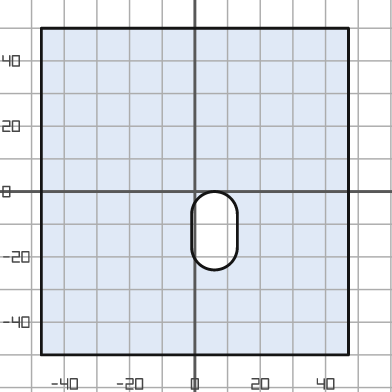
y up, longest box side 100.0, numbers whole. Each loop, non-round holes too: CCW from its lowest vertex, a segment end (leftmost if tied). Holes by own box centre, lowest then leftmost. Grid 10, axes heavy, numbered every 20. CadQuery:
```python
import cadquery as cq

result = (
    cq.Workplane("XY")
    .moveTo(-47.0, -50.0)
    .lineTo(47.0, -50.0)
    .lineTo(47.0, 50.0)
    .lineTo(-47.0, 50.0)
    .close()
    .moveTo(-1.0, -17.0)
    .threePointArc((6.0, -24.0), (13.0, -17.0))
    .lineTo(13.0, -7.0)
    .threePointArc((6.0, 0.0), (-1.0, -7.0))
    .close()
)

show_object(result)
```